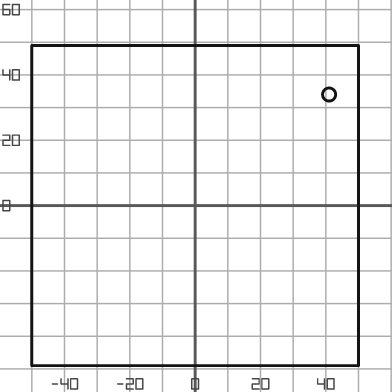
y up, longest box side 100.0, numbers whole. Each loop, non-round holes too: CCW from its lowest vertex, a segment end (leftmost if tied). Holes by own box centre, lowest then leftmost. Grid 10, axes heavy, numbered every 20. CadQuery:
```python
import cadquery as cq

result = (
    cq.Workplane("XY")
    .moveTo(-50.0, -49.0)
    .lineTo(50.0, -49.0)
    .lineTo(50.0, 49.0)
    .lineTo(-50.0, 49.0)
    .close()
    .moveTo(41.0, 34.0)
    .circle(2.0)
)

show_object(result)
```